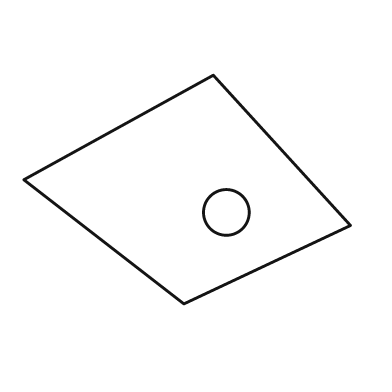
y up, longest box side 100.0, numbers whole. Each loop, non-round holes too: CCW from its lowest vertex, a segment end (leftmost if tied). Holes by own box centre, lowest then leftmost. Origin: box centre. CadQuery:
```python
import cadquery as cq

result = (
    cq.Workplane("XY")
    .moveTo(-1.0, -35.0)
    .lineTo(50.0, -11.0)
    .lineTo(8.0, 35.0)
    .lineTo(-50.0, 3.0)
    .close()
    .moveTo(12.0, -7.0)
    .circle(7.0)
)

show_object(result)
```